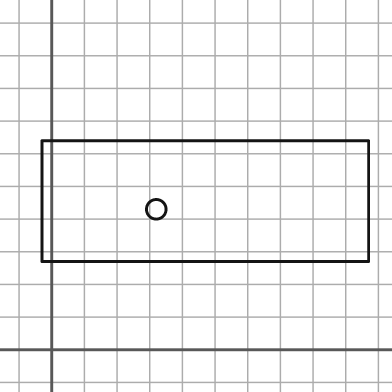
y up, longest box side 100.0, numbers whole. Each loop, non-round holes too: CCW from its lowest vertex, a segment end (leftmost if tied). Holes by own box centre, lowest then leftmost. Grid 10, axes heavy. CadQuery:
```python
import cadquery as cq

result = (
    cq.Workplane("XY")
    .moveTo(-3.0, 27.0)
    .lineTo(97.0, 27.0)
    .lineTo(97.0, 64.0)
    .lineTo(-3.0, 64.0)
    .close()
    .moveTo(32.0, 43.0)
    .circle(3.0)
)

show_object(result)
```